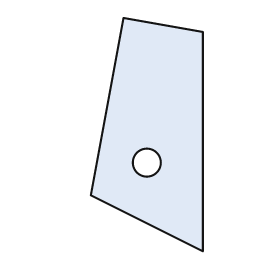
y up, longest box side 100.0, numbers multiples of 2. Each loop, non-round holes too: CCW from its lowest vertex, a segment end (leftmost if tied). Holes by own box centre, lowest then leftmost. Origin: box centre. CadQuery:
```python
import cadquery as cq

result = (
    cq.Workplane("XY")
    .moveTo(24.0, -50.0)
    .lineTo(24.0, 44.0)
    .lineTo(-10.0, 50.0)
    .lineTo(-24.0, -26.0)
    .close()
    .moveTo(0.0, -12.0)
    .circle(6.0)
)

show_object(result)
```